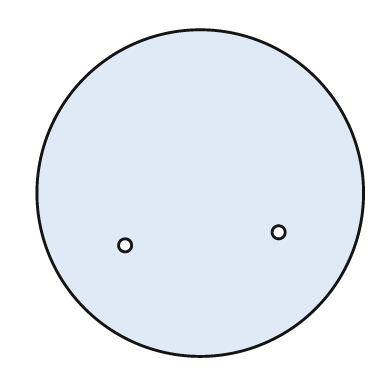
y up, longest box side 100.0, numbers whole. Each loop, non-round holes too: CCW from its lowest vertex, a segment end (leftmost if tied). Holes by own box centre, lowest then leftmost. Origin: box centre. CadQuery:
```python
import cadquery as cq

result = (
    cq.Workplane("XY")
    .moveTo(0.0, 0.0)
    .circle(50.0)
    .moveTo(-23.0, -16.0)
    .circle(2.0)
    .moveTo(24.0, -12.0)
    .circle(2.0)
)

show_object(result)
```